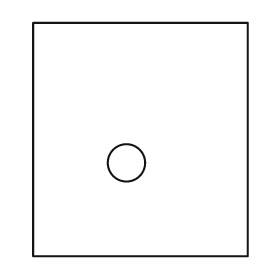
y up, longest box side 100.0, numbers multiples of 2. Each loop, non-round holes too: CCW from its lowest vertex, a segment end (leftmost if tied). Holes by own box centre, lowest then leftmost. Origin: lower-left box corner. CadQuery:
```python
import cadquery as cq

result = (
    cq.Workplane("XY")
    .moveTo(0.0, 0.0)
    .lineTo(92.0, 0.0)
    .lineTo(92.0, 100.0)
    .lineTo(0.0, 100.0)
    .close()
    .moveTo(40.0, 40.0)
    .circle(8.0)
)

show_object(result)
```